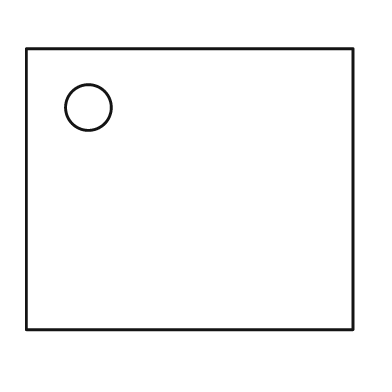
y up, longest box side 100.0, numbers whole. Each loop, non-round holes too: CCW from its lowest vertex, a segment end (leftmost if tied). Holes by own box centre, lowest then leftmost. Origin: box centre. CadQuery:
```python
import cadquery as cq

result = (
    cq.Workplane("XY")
    .moveTo(-50.0, -43.0)
    .lineTo(50.0, -43.0)
    .lineTo(50.0, 43.0)
    .lineTo(-50.0, 43.0)
    .close()
    .moveTo(-31.0, 25.0)
    .circle(7.0)
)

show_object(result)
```